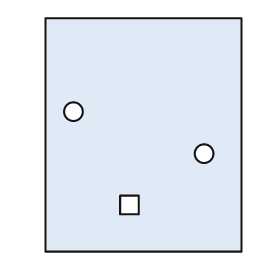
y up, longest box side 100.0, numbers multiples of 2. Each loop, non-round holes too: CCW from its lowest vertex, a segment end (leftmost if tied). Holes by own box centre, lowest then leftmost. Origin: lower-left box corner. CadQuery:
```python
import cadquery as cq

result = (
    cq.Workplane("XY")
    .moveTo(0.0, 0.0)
    .lineTo(84.0, 0.0)
    .lineTo(84.0, 100.0)
    .lineTo(0.0, 100.0)
    .close()
    .moveTo(32.0, 16.0)
    .lineTo(40.0, 16.0)
    .lineTo(40.0, 24.0)
    .lineTo(32.0, 24.0)
    .close()
    .moveTo(68.0, 42.0)
    .circle(4.0)
    .moveTo(12.0, 60.0)
    .circle(4.0)
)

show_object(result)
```